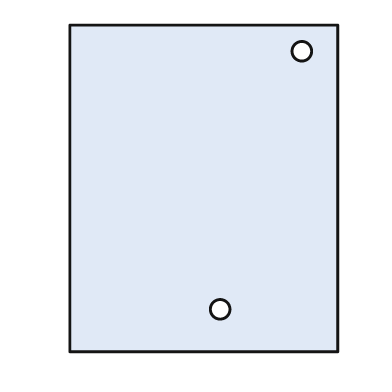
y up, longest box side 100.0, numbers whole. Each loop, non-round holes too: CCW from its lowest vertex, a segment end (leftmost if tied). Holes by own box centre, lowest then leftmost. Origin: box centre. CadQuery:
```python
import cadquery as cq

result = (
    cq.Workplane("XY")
    .moveTo(-41.0, -50.0)
    .lineTo(41.0, -50.0)
    .lineTo(41.0, 50.0)
    .lineTo(-41.0, 50.0)
    .close()
    .moveTo(5.0, -37.0)
    .circle(3.0)
    .moveTo(30.0, 42.0)
    .circle(3.0)
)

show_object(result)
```